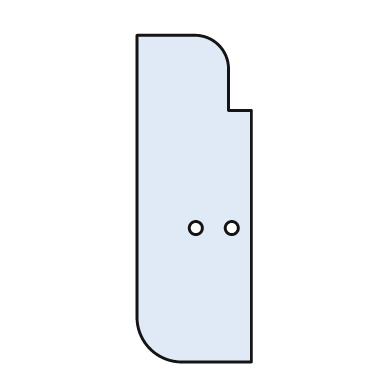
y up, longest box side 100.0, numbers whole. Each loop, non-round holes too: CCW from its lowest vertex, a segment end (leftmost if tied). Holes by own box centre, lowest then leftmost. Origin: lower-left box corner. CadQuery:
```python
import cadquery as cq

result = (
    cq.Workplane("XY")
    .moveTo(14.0, 0.0)
    .lineTo(35.0, 0.0)
    .lineTo(35.0, 77.0)
    .lineTo(28.0, 77.0)
    .lineTo(28.0, 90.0)
    .threePointArc((25.0, 97.0), (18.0, 100.0))
    .lineTo(0.0, 100.0)
    .lineTo(0.0, 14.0)
    .threePointArc((4.0, 4.0), (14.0, 0.0))
    .close()
    .moveTo(18.0, 41.0)
    .circle(2.0)
    .moveTo(29.0, 41.0)
    .circle(2.0)
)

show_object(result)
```